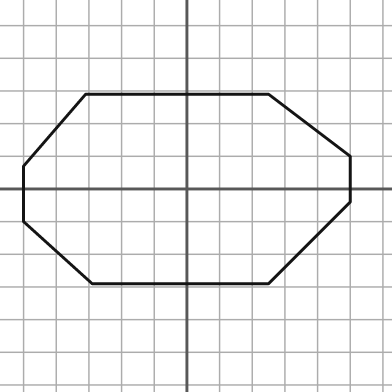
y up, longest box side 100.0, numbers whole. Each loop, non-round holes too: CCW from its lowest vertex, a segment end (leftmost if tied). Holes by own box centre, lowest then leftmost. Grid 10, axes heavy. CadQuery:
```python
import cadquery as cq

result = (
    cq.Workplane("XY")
    .moveTo(-29.0, -29.0)
    .lineTo(25.0, -29.0)
    .lineTo(50.0, -4.0)
    .lineTo(50.0, 10.0)
    .lineTo(25.0, 29.0)
    .lineTo(-31.0, 29.0)
    .lineTo(-50.0, 7.0)
    .lineTo(-50.0, -10.0)
    .close()
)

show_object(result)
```